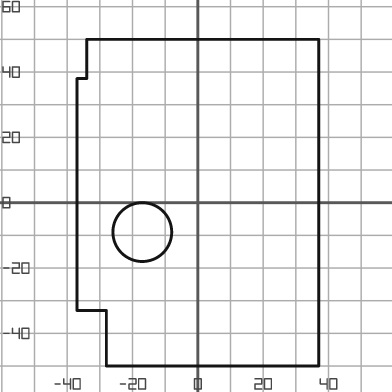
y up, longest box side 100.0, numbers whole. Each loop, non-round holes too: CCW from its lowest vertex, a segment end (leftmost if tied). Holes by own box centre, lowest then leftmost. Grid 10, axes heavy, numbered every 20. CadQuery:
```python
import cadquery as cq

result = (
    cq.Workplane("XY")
    .moveTo(-28.0, -50.0)
    .lineTo(37.0, -50.0)
    .lineTo(37.0, 50.0)
    .lineTo(-34.0, 50.0)
    .lineTo(-34.0, 38.0)
    .lineTo(-37.0, 38.0)
    .lineTo(-37.0, -33.0)
    .lineTo(-28.0, -33.0)
    .close()
    .moveTo(-17.0, -9.0)
    .circle(9.0)
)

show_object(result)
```